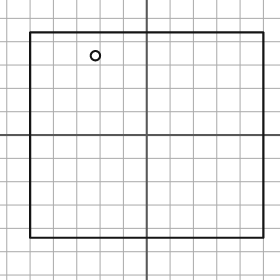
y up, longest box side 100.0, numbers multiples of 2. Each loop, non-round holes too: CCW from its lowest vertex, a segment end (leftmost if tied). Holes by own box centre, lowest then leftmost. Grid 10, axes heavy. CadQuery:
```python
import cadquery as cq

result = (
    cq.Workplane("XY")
    .moveTo(-50.0, -44.0)
    .lineTo(50.0, -44.0)
    .lineTo(50.0, 44.0)
    .lineTo(-50.0, 44.0)
    .close()
    .moveTo(-22.0, 34.0)
    .circle(2.0)
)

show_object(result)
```